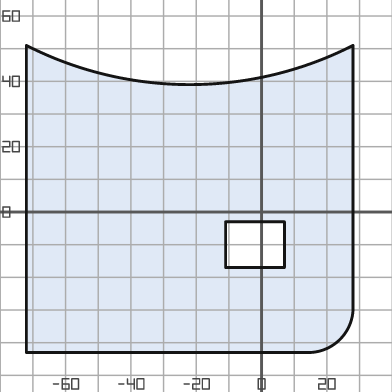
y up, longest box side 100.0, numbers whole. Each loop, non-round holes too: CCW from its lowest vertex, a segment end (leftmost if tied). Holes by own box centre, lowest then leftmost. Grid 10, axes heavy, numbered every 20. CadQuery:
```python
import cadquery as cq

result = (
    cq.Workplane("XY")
    .moveTo(-72.0, -43.0)
    .lineTo(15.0, -43.0)
    .threePointArc((24.0, -39.0), (28.0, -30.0))
    .lineTo(28.0, 51.0)
    .threePointArc((-22.0, 39.0), (-72.0, 51.0))
    .close()
    .moveTo(-11.0, -17.0)
    .lineTo(7.0, -17.0)
    .lineTo(7.0, -3.0)
    .lineTo(-11.0, -3.0)
    .close()
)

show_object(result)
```